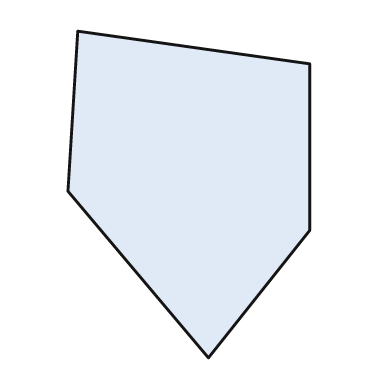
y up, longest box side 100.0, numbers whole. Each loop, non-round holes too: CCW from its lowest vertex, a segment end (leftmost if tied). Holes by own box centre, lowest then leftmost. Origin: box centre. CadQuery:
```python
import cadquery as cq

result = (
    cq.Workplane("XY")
    .moveTo(6.0, -50.0)
    .lineTo(37.0, -11.0)
    .lineTo(37.0, 40.0)
    .lineTo(-34.0, 50.0)
    .lineTo(-37.0, 1.0)
    .close()
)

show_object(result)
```